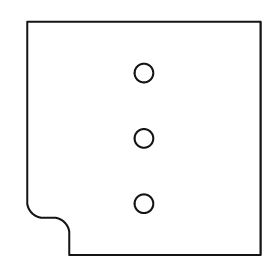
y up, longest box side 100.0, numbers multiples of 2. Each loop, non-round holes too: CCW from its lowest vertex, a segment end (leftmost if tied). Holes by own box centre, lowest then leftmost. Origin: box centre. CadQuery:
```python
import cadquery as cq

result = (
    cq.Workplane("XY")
    .moveTo(-32.0, -50.0)
    .lineTo(50.0, -50.0)
    .lineTo(50.0, 50.0)
    .lineTo(-50.0, 50.0)
    .lineTo(-50.0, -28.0)
    .threePointArc((-48.0, -32.0), (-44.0, -34.0))
    .lineTo(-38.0, -34.0)
    .threePointArc((-34.0, -36.0), (-32.0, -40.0))
    .close()
    .moveTo(0.0, -28.0)
    .circle(4.0)
    .moveTo(0.0, 0.0)
    .circle(4.0)
    .moveTo(0.0, 28.0)
    .circle(4.0)
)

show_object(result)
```